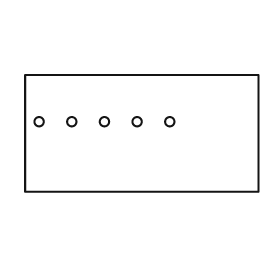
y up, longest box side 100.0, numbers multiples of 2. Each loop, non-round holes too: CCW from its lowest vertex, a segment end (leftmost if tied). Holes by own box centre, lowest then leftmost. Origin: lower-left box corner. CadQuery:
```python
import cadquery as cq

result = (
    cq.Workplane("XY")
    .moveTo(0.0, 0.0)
    .lineTo(100.0, 0.0)
    .lineTo(100.0, 50.0)
    .lineTo(0.0, 50.0)
    .close()
    .moveTo(6.0, 30.0)
    .circle(2.0)
    .moveTo(20.0, 30.0)
    .circle(2.0)
    .moveTo(34.0, 30.0)
    .circle(2.0)
    .moveTo(48.0, 30.0)
    .circle(2.0)
    .moveTo(62.0, 30.0)
    .circle(2.0)
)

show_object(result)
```